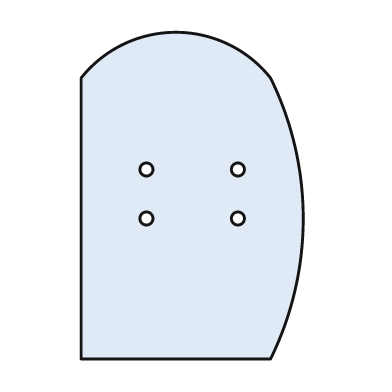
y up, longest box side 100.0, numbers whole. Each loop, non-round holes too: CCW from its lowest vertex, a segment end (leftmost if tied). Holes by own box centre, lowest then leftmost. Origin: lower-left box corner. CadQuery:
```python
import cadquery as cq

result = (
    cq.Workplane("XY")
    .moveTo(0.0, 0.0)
    .lineTo(58.0, 0.0)
    .threePointArc((68.0, 43.0), (58.0, 86.0))
    .threePointArc((29.0, 100.0), (0.0, 86.0))
    .close()
    .moveTo(20.0, 43.0)
    .circle(2.0)
    .moveTo(48.0, 43.0)
    .circle(2.0)
    .moveTo(20.0, 58.0)
    .circle(2.0)
    .moveTo(48.0, 58.0)
    .circle(2.0)
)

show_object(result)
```